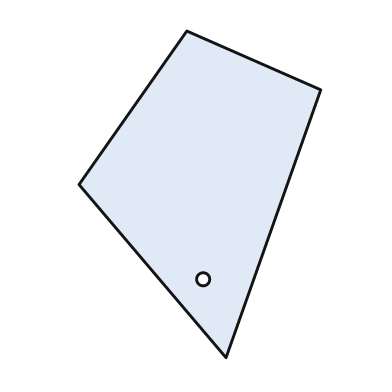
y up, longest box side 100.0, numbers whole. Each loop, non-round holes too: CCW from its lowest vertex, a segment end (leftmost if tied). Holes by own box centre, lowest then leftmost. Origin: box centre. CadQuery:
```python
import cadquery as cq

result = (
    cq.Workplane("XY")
    .moveTo(8.0, -50.0)
    .lineTo(37.0, 32.0)
    .lineTo(-4.0, 50.0)
    .lineTo(-37.0, 3.0)
    .close()
    .moveTo(1.0, -26.0)
    .circle(2.0)
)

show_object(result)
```